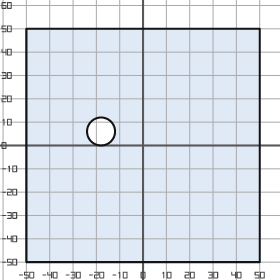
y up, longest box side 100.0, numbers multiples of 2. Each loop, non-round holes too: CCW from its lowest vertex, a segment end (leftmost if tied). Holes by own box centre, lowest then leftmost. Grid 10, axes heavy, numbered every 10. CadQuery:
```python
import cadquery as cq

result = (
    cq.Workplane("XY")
    .moveTo(-50.0, -50.0)
    .lineTo(50.0, -50.0)
    .lineTo(50.0, 50.0)
    .lineTo(-50.0, 50.0)
    .close()
    .moveTo(-18.0, 6.0)
    .circle(6.0)
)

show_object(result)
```